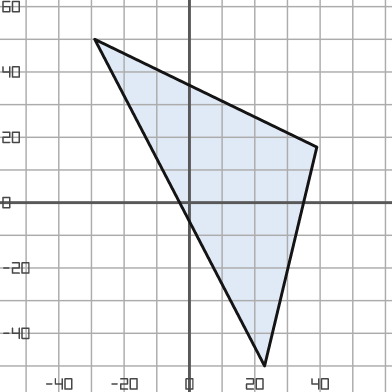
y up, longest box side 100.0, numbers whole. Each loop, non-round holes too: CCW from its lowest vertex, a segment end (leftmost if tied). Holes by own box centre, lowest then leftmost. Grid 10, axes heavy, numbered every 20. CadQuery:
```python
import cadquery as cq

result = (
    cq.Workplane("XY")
    .moveTo(23.0, -50.0)
    .lineTo(39.0, 17.0)
    .lineTo(-29.0, 50.0)
    .close()
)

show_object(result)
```